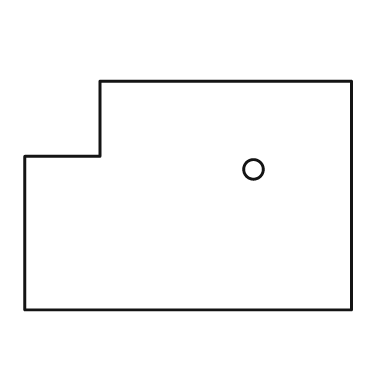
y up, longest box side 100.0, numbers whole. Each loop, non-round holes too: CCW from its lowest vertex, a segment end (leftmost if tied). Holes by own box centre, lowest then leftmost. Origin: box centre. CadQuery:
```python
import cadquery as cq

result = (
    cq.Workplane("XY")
    .moveTo(-50.0, -35.0)
    .lineTo(50.0, -35.0)
    .lineTo(50.0, 35.0)
    .lineTo(-27.0, 35.0)
    .lineTo(-27.0, 12.0)
    .lineTo(-50.0, 12.0)
    .close()
    .moveTo(20.0, 8.0)
    .circle(3.0)
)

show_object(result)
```